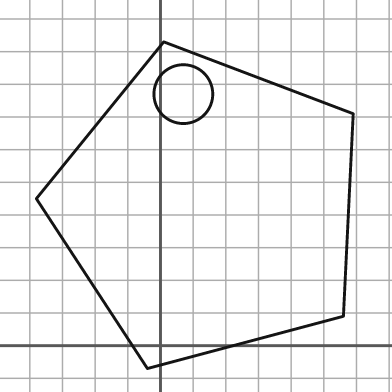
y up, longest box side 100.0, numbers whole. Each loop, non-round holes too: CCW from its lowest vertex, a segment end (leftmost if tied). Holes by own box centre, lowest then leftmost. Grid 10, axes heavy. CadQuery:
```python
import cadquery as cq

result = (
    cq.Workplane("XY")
    .moveTo(-4.0, -7.0)
    .lineTo(56.0, 9.0)
    .lineTo(59.0, 71.0)
    .lineTo(1.0, 93.0)
    .lineTo(-38.0, 45.0)
    .close()
    .moveTo(7.0, 77.0)
    .circle(9.0)
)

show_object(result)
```